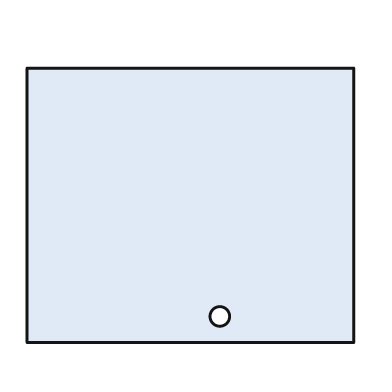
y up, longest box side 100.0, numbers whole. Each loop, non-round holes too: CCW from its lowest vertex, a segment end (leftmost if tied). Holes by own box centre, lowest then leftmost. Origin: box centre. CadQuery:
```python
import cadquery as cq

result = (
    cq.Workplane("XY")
    .moveTo(-50.0, -42.0)
    .lineTo(50.0, -42.0)
    .lineTo(50.0, 42.0)
    .lineTo(-50.0, 42.0)
    .close()
    .moveTo(9.0, -34.0)
    .circle(3.0)
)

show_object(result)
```